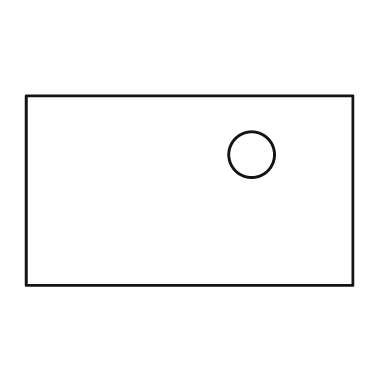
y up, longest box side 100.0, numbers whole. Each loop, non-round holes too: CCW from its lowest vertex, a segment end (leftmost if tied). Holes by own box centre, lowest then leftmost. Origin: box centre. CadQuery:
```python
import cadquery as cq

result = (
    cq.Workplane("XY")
    .moveTo(-50.0, -29.0)
    .lineTo(50.0, -29.0)
    .lineTo(50.0, 29.0)
    .lineTo(-50.0, 29.0)
    .close()
    .moveTo(19.0, 11.0)
    .circle(7.0)
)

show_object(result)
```